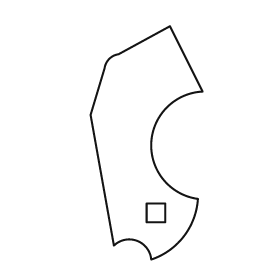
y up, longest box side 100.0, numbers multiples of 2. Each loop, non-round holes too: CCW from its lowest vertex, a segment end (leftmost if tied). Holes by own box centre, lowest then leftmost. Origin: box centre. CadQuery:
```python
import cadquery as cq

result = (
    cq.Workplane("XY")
    .moveTo(2.0, -50.0)
    .threePointArc((16.0, -40.0), (22.0, -24.0))
    .threePointArc((2.0, 0.0), (24.0, 22.0))
    .lineTo(10.0, 50.0)
    .lineTo(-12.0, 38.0)
    .threePointArc((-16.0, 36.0), (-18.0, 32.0))
    .lineTo(-24.0, 12.0)
    .lineTo(-14.0, -44.0)
    .threePointArc((-4.0, -42.0), (2.0, -50.0))
    .close()
    .moveTo(0.0, -34.0)
    .lineTo(8.0, -34.0)
    .lineTo(8.0, -26.0)
    .lineTo(0.0, -26.0)
    .close()
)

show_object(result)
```